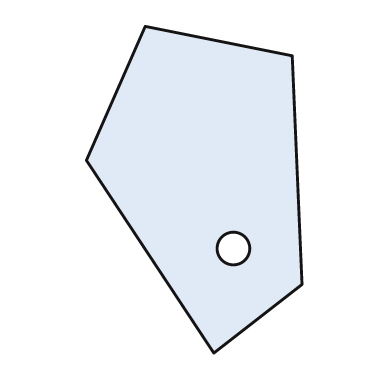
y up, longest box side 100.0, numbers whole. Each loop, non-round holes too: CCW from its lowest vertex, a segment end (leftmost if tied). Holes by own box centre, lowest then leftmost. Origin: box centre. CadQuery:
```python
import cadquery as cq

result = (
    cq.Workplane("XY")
    .moveTo(6.0, -50.0)
    .lineTo(33.0, -29.0)
    .lineTo(30.0, 41.0)
    .lineTo(-15.0, 50.0)
    .lineTo(-33.0, 9.0)
    .close()
    .moveTo(12.0, -18.0)
    .circle(5.0)
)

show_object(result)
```